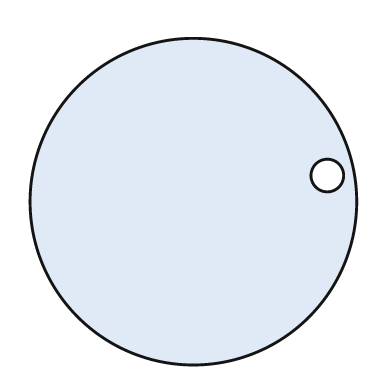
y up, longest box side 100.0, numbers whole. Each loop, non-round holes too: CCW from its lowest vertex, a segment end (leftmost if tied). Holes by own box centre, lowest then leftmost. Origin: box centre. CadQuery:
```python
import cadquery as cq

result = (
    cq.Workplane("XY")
    .moveTo(0.0, 0.0)
    .circle(50.0)
    .moveTo(41.0, 8.0)
    .circle(5.0)
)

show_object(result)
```